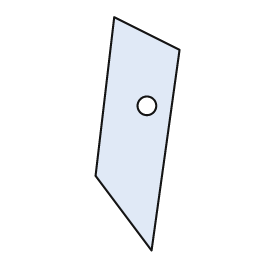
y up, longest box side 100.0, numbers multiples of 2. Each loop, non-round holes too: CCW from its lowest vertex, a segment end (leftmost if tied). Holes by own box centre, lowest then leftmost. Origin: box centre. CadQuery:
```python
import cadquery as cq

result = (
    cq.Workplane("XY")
    .moveTo(6.0, -50.0)
    .lineTo(18.0, 36.0)
    .lineTo(-10.0, 50.0)
    .lineTo(-18.0, -18.0)
    .close()
    .moveTo(4.0, 12.0)
    .circle(4.0)
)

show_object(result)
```